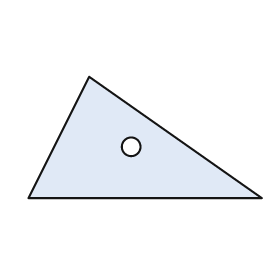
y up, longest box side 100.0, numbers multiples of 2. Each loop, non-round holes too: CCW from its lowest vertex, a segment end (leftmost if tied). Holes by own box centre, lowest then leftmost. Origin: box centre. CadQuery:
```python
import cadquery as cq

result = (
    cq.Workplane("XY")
    .moveTo(-50.0, -26.0)
    .lineTo(50.0, -26.0)
    .lineTo(-24.0, 26.0)
    .close()
    .moveTo(-6.0, -4.0)
    .circle(4.0)
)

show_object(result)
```